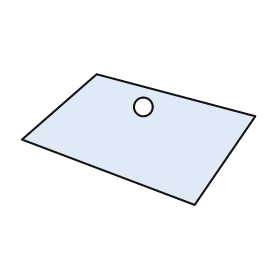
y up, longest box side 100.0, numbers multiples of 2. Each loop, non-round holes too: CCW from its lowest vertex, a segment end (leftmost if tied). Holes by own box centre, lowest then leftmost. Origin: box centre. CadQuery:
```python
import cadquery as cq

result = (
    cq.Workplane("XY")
    .moveTo(24.0, -28.0)
    .lineTo(50.0, 10.0)
    .lineTo(-18.0, 28.0)
    .lineTo(-50.0, 0.0)
    .close()
    .moveTo(2.0, 14.0)
    .circle(4.0)
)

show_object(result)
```